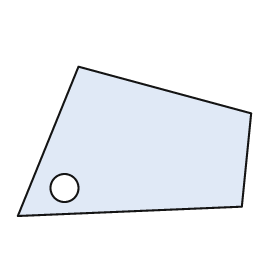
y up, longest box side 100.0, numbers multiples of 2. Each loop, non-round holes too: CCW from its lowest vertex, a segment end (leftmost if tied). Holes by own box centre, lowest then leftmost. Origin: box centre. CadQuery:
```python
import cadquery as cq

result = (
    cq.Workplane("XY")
    .moveTo(-50.0, -32.0)
    .lineTo(46.0, -28.0)
    .lineTo(50.0, 12.0)
    .lineTo(-24.0, 32.0)
    .close()
    .moveTo(-30.0, -20.0)
    .circle(6.0)
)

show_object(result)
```